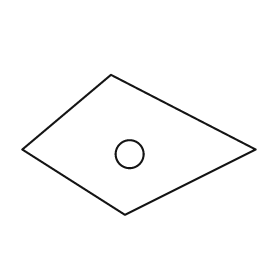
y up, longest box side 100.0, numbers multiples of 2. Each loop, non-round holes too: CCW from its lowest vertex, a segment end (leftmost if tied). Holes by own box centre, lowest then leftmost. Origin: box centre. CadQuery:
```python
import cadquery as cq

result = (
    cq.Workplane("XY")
    .moveTo(-6.0, -30.0)
    .lineTo(50.0, -2.0)
    .lineTo(-12.0, 30.0)
    .lineTo(-50.0, -2.0)
    .close()
    .moveTo(-4.0, -4.0)
    .circle(6.0)
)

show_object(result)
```